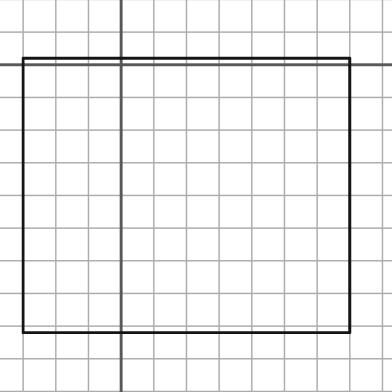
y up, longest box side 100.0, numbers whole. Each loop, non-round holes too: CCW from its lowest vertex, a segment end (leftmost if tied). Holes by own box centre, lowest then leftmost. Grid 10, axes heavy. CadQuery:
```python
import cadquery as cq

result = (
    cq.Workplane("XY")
    .moveTo(-30.0, -82.0)
    .lineTo(70.0, -82.0)
    .lineTo(70.0, 2.0)
    .lineTo(-30.0, 2.0)
    .close()
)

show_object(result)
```